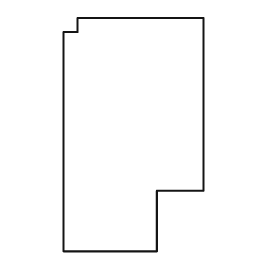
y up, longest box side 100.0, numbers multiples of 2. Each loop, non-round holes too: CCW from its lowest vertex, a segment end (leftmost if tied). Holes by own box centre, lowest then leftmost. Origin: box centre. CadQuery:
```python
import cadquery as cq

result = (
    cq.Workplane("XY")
    .moveTo(-30.0, -50.0)
    .lineTo(10.0, -50.0)
    .lineTo(10.0, -24.0)
    .lineTo(30.0, -24.0)
    .lineTo(30.0, 50.0)
    .lineTo(-24.0, 50.0)
    .lineTo(-24.0, 44.0)
    .lineTo(-30.0, 44.0)
    .close()
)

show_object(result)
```